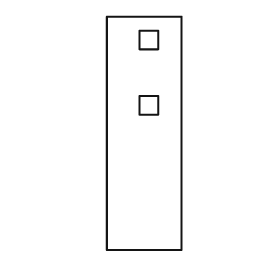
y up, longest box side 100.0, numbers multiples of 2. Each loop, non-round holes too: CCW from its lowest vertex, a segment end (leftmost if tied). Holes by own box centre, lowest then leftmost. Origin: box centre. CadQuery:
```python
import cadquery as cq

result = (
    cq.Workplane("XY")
    .moveTo(-16.0, -50.0)
    .lineTo(16.0, -50.0)
    .lineTo(16.0, 50.0)
    .lineTo(-16.0, 50.0)
    .close()
    .moveTo(-2.0, 8.0)
    .lineTo(6.0, 8.0)
    .lineTo(6.0, 16.0)
    .lineTo(-2.0, 16.0)
    .close()
    .moveTo(-2.0, 36.0)
    .lineTo(6.0, 36.0)
    .lineTo(6.0, 44.0)
    .lineTo(-2.0, 44.0)
    .close()
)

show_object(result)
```